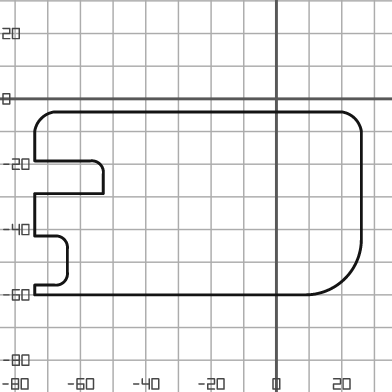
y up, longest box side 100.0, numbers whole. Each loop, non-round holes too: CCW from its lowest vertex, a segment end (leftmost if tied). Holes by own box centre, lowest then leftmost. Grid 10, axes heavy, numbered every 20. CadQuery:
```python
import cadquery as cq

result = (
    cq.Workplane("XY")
    .moveTo(-74.0, -60.0)
    .lineTo(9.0, -60.0)
    .threePointArc((21.0, -55.0), (26.0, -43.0))
    .lineTo(26.0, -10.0)
    .threePointArc((24.0, -6.0), (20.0, -4.0))
    .lineTo(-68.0, -4.0)
    .threePointArc((-72.0, -6.0), (-74.0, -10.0))
    .lineTo(-74.0, -19.0)
    .lineTo(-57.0, -19.0)
    .threePointArc((-54.0, -20.0), (-53.0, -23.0))
    .lineTo(-53.0, -29.0)
    .lineTo(-74.0, -29.0)
    .lineTo(-74.0, -42.0)
    .lineTo(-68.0, -42.0)
    .threePointArc((-65.0, -43.0), (-64.0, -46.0))
    .lineTo(-64.0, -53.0)
    .threePointArc((-65.0, -56.0), (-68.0, -57.0))
    .lineTo(-74.0, -57.0)
    .close()
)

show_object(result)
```